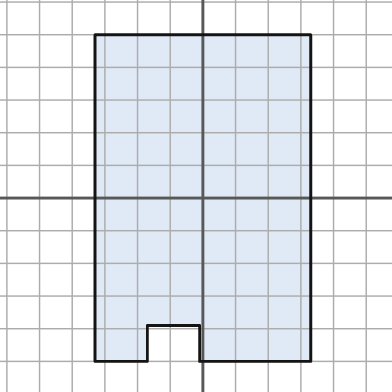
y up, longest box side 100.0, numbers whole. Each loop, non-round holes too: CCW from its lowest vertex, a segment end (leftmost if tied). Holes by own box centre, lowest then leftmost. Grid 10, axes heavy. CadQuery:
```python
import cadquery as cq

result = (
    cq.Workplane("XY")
    .moveTo(-33.0, -50.0)
    .lineTo(-17.0, -50.0)
    .lineTo(-17.0, -39.0)
    .lineTo(-1.0, -39.0)
    .lineTo(-1.0, -50.0)
    .lineTo(33.0, -50.0)
    .lineTo(33.0, 50.0)
    .lineTo(-33.0, 50.0)
    .close()
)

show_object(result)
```